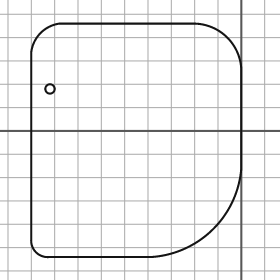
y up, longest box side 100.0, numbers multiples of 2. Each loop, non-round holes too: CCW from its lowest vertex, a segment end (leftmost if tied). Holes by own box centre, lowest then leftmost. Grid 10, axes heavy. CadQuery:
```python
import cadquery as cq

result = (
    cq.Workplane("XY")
    .moveTo(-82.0, -54.0)
    .lineTo(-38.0, -54.0)
    .threePointArc((-12.0, -42.0), (0.0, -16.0))
    .lineTo(0.0, 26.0)
    .threePointArc((-6.0, 40.0), (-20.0, 46.0))
    .lineTo(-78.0, 46.0)
    .threePointArc((-86.0, 42.0), (-90.0, 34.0))
    .lineTo(-90.0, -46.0)
    .threePointArc((-88.0, -52.0), (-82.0, -54.0))
    .close()
    .moveTo(-82.0, 18.0)
    .circle(2.0)
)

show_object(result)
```